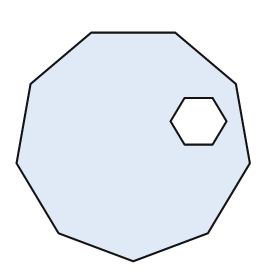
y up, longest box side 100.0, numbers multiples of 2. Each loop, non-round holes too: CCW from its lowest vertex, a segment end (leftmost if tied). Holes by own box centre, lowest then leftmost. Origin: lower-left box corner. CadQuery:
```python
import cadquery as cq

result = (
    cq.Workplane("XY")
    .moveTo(50.0, 0.0)
    .lineTo(82.0, 12.0)
    .lineTo(100.0, 42.0)
    .lineTo(94.0, 76.0)
    .lineTo(68.0, 98.0)
    .lineTo(32.0, 98.0)
    .lineTo(6.0, 76.0)
    .lineTo(0.0, 42.0)
    .lineTo(18.0, 12.0)
    .close()
    .moveTo(72.0, 50.0)
    .lineTo(84.0, 50.0)
    .lineTo(90.0, 60.0)
    .lineTo(84.0, 70.0)
    .lineTo(72.0, 70.0)
    .lineTo(66.0, 60.0)
    .close()
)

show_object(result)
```